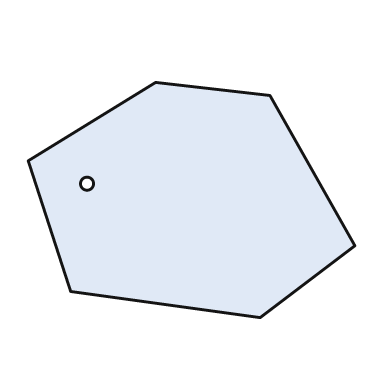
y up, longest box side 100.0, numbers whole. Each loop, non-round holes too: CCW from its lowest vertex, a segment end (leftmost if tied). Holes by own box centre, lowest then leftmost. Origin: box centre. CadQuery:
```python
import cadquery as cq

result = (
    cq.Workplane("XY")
    .moveTo(21.0, -36.0)
    .lineTo(50.0, -14.0)
    .lineTo(24.0, 32.0)
    .lineTo(-11.0, 36.0)
    .lineTo(-50.0, 12.0)
    .lineTo(-37.0, -28.0)
    .close()
    .moveTo(-32.0, 5.0)
    .circle(2.0)
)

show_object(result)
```